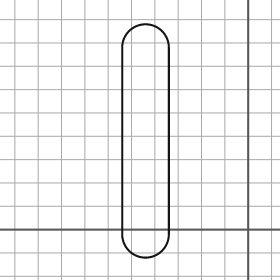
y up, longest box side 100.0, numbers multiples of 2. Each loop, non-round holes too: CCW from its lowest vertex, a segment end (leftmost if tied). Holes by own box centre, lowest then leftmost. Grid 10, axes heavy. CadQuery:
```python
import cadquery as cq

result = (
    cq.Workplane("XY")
    .moveTo(-54.0, -2.0)
    .threePointArc((-44.0, -12.0), (-34.0, -2.0))
    .lineTo(-34.0, 78.0)
    .threePointArc((-44.0, 88.0), (-54.0, 78.0))
    .close()
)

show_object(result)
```